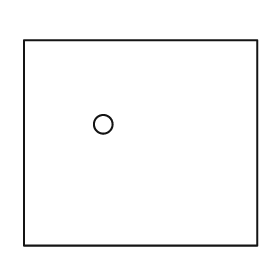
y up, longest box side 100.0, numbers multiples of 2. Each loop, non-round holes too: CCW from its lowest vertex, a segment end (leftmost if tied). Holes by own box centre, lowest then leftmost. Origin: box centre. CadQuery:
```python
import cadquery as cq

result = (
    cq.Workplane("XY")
    .moveTo(-50.0, -44.0)
    .lineTo(50.0, -44.0)
    .lineTo(50.0, 44.0)
    .lineTo(-50.0, 44.0)
    .close()
    .moveTo(-16.0, 8.0)
    .circle(4.0)
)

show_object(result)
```